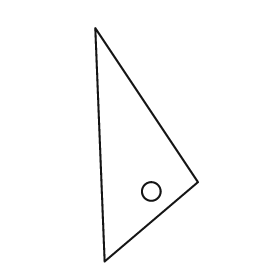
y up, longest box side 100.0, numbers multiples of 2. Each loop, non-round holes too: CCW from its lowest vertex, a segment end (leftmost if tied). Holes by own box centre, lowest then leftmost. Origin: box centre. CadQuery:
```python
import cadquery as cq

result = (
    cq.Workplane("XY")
    .moveTo(-18.0, -50.0)
    .lineTo(22.0, -16.0)
    .lineTo(-22.0, 50.0)
    .close()
    .moveTo(2.0, -20.0)
    .circle(4.0)
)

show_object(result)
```